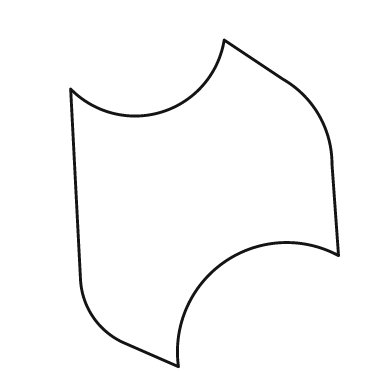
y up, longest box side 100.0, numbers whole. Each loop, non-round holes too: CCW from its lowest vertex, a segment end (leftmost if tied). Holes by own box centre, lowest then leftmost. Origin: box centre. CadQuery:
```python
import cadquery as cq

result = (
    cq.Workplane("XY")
    .moveTo(-8.0, -50.0)
    .threePointArc((6.0, -18.0), (41.0, -16.0))
    .lineTo(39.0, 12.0)
    .threePointArc((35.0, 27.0), (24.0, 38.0))
    .lineTo(6.0, 50.0)
    .threePointArc((-13.0, 28.0), (-41.0, 35.0))
    .lineTo(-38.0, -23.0)
    .threePointArc((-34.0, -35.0), (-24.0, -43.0))
    .close()
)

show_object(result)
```